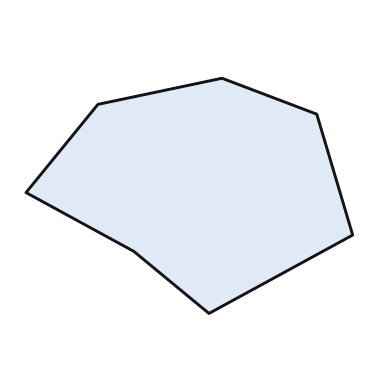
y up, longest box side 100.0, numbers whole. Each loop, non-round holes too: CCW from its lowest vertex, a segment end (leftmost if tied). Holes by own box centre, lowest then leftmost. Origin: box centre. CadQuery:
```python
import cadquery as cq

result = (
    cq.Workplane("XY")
    .moveTo(6.0, -36.0)
    .lineTo(50.0, -12.0)
    .lineTo(39.0, 25.0)
    .lineTo(10.0, 36.0)
    .lineTo(-28.0, 28.0)
    .lineTo(-50.0, 1.0)
    .lineTo(-17.0, -17.0)
    .close()
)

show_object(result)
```